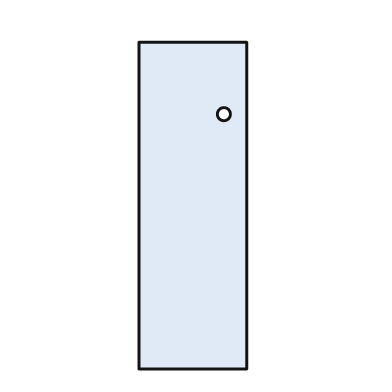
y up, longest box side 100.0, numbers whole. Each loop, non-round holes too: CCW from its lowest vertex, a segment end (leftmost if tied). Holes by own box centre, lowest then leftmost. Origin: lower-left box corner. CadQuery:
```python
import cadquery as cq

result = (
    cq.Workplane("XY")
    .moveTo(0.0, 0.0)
    .lineTo(33.0, 0.0)
    .lineTo(33.0, 100.0)
    .lineTo(0.0, 100.0)
    .close()
    .moveTo(26.0, 78.0)
    .circle(2.0)
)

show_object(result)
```